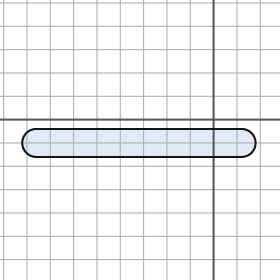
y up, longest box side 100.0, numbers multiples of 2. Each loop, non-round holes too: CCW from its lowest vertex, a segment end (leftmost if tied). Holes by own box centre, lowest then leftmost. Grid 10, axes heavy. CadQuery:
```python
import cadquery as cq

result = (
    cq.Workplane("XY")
    .moveTo(-76.0, -16.0)
    .lineTo(12.0, -16.0)
    .threePointArc((18.0, -10.0), (12.0, -4.0))
    .lineTo(-76.0, -4.0)
    .threePointArc((-82.0, -10.0), (-76.0, -16.0))
    .close()
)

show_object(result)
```